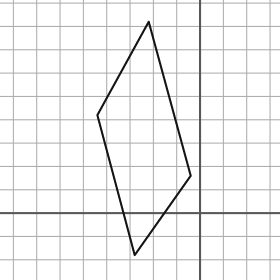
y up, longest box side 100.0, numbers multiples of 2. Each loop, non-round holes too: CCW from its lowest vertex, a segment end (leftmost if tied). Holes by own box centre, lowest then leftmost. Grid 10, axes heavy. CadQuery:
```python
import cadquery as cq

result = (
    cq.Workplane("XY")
    .moveTo(-28.0, -18.0)
    .lineTo(-4.0, 16.0)
    .lineTo(-22.0, 82.0)
    .lineTo(-44.0, 42.0)
    .close()
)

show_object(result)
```